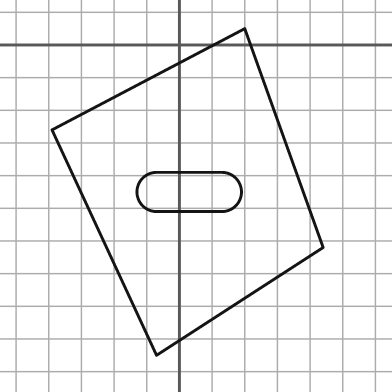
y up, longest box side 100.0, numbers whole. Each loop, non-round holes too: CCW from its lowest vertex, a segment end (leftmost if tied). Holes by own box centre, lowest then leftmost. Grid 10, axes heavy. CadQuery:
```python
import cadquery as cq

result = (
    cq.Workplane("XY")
    .moveTo(-7.0, -95.0)
    .lineTo(44.0, -62.0)
    .lineTo(20.0, 5.0)
    .lineTo(-39.0, -26.0)
    .close()
    .moveTo(-7.0, -51.0)
    .lineTo(13.0, -51.0)
    .threePointArc((19.0, -45.0), (13.0, -39.0))
    .lineTo(-7.0, -39.0)
    .threePointArc((-13.0, -45.0), (-7.0, -51.0))
    .close()
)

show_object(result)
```